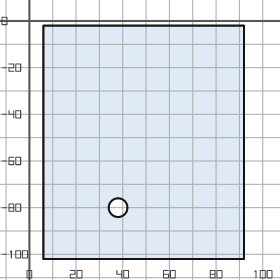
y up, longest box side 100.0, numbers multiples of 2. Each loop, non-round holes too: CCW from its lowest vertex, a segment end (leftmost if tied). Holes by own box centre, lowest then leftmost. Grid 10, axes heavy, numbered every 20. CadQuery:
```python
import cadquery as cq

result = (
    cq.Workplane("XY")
    .moveTo(6.0, -102.0)
    .lineTo(92.0, -102.0)
    .lineTo(92.0, -2.0)
    .lineTo(6.0, -2.0)
    .close()
    .moveTo(38.0, -80.0)
    .circle(4.0)
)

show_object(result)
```